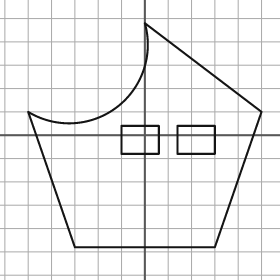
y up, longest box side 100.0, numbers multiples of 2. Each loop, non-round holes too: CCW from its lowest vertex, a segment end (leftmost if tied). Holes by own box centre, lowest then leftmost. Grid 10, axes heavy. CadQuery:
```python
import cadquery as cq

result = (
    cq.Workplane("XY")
    .moveTo(-30.0, -48.0)
    .lineTo(30.0, -48.0)
    .lineTo(50.0, 10.0)
    .lineTo(0.0, 48.0)
    .threePointArc((-12.0, 12.0), (-50.0, 10.0))
    .close()
    .moveTo(-10.0, -8.0)
    .lineTo(6.0, -8.0)
    .lineTo(6.0, 4.0)
    .lineTo(-10.0, 4.0)
    .close()
    .moveTo(14.0, -8.0)
    .lineTo(30.0, -8.0)
    .lineTo(30.0, 4.0)
    .lineTo(14.0, 4.0)
    .close()
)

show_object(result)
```